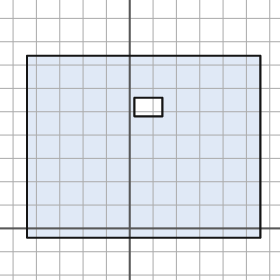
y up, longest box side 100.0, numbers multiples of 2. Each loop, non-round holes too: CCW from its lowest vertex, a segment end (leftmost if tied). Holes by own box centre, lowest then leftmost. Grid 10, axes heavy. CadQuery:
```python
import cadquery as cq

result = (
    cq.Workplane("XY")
    .moveTo(-44.0, -4.0)
    .lineTo(56.0, -4.0)
    .lineTo(56.0, 74.0)
    .lineTo(-44.0, 74.0)
    .close()
    .moveTo(2.0, 48.0)
    .lineTo(14.0, 48.0)
    .lineTo(14.0, 56.0)
    .lineTo(2.0, 56.0)
    .close()
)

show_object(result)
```